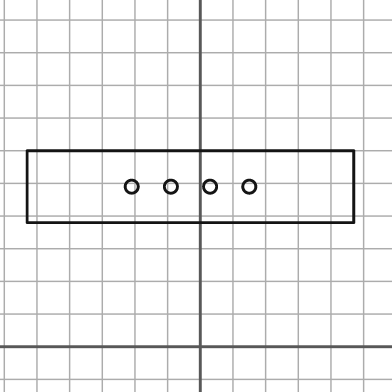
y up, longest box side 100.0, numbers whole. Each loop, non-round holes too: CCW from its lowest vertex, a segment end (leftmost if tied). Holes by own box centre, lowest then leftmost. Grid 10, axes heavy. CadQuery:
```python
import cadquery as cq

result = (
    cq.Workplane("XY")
    .moveTo(-53.0, 38.0)
    .lineTo(47.0, 38.0)
    .lineTo(47.0, 60.0)
    .lineTo(-53.0, 60.0)
    .close()
    .moveTo(-21.0, 49.0)
    .circle(2.0)
    .moveTo(-9.0, 49.0)
    .circle(2.0)
    .moveTo(3.0, 49.0)
    .circle(2.0)
    .moveTo(15.0, 49.0)
    .circle(2.0)
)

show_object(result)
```